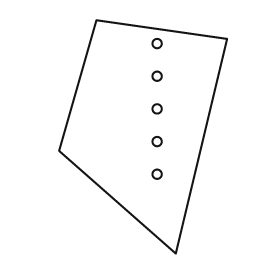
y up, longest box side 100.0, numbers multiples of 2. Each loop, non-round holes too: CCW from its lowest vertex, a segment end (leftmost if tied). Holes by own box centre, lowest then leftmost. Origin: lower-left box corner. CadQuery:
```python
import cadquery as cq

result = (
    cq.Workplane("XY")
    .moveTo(50.0, 0.0)
    .lineTo(72.0, 92.0)
    .lineTo(16.0, 100.0)
    .lineTo(0.0, 44.0)
    .close()
    .moveTo(42.0, 34.0)
    .circle(2.0)
    .moveTo(42.0, 48.0)
    .circle(2.0)
    .moveTo(42.0, 62.0)
    .circle(2.0)
    .moveTo(42.0, 76.0)
    .circle(2.0)
    .moveTo(42.0, 90.0)
    .circle(2.0)
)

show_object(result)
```